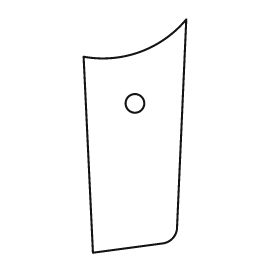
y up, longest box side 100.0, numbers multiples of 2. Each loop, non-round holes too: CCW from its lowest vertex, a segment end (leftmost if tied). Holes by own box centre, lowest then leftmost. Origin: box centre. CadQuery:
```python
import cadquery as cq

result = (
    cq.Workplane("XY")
    .moveTo(-18.0, -50.0)
    .lineTo(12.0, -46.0)
    .threePointArc((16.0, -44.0), (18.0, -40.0))
    .lineTo(22.0, 50.0)
    .threePointArc((2.0, 36.0), (-22.0, 34.0))
    .close()
    .moveTo(0.0, 14.0)
    .circle(4.0)
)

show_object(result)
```